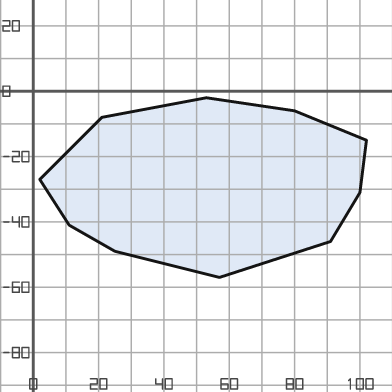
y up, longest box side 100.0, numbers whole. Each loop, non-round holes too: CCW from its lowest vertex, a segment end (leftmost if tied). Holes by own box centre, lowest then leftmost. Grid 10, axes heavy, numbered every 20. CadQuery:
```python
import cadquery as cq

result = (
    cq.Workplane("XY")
    .moveTo(57.0, -57.0)
    .lineTo(91.0, -46.0)
    .lineTo(100.0, -31.0)
    .lineTo(102.0, -15.0)
    .lineTo(80.0, -6.0)
    .lineTo(53.0, -2.0)
    .lineTo(21.0, -8.0)
    .lineTo(2.0, -27.0)
    .lineTo(11.0, -41.0)
    .lineTo(25.0, -49.0)
    .close()
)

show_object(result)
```